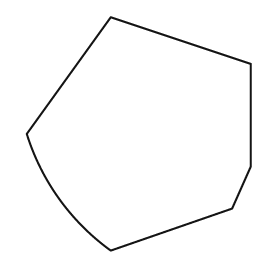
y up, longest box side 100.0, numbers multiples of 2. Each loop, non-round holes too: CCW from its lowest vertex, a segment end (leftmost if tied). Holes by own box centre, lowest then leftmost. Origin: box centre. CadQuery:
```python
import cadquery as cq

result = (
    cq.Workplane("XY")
    .moveTo(-12.0, -50.0)
    .lineTo(40.0, -32.0)
    .lineTo(48.0, -14.0)
    .lineTo(48.0, 30.0)
    .lineTo(-12.0, 50.0)
    .lineTo(-48.0, 0.0)
    .threePointArc((-34.0, -28.0), (-12.0, -50.0))
    .close()
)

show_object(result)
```